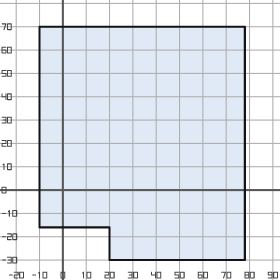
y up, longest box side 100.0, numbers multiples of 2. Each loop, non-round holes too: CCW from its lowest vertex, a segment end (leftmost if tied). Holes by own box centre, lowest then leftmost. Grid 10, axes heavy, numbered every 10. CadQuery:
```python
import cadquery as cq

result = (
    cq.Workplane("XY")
    .moveTo(20.0, -30.0)
    .lineTo(78.0, -30.0)
    .lineTo(78.0, 70.0)
    .lineTo(-10.0, 70.0)
    .lineTo(-10.0, -16.0)
    .lineTo(20.0, -16.0)
    .close()
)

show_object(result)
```